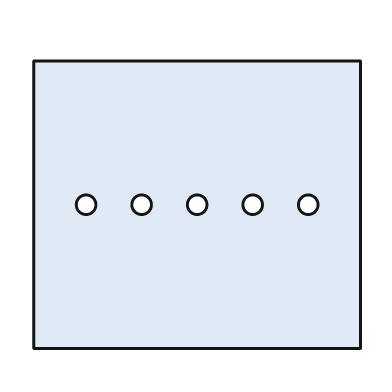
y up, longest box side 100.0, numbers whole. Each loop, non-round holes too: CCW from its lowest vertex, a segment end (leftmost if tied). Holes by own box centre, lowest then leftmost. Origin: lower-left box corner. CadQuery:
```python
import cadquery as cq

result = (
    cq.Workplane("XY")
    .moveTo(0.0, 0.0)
    .lineTo(100.0, 0.0)
    .lineTo(100.0, 88.0)
    .lineTo(0.0, 88.0)
    .close()
    .moveTo(16.0, 44.0)
    .circle(3.0)
    .moveTo(33.0, 44.0)
    .circle(3.0)
    .moveTo(50.0, 44.0)
    .circle(3.0)
    .moveTo(67.0, 44.0)
    .circle(3.0)
    .moveTo(84.0, 44.0)
    .circle(3.0)
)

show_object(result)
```